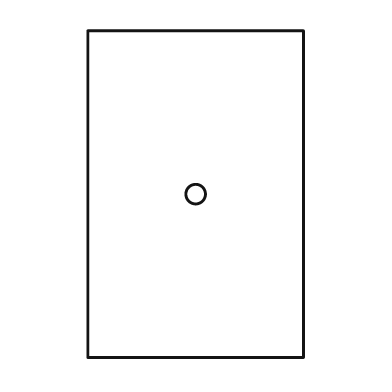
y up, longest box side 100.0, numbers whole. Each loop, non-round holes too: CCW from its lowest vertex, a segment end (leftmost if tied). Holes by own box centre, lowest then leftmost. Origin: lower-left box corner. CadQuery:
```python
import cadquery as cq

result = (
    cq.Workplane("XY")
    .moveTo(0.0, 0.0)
    .lineTo(66.0, 0.0)
    .lineTo(66.0, 100.0)
    .lineTo(0.0, 100.0)
    .close()
    .moveTo(33.0, 50.0)
    .circle(3.0)
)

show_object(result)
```